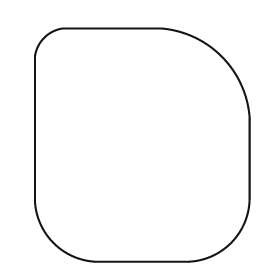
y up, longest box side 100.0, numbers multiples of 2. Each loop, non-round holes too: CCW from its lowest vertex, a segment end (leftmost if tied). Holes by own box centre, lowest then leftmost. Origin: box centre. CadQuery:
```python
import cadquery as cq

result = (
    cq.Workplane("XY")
    .moveTo(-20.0, -50.0)
    .lineTo(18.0, -50.0)
    .threePointArc((38.0, -42.0), (46.0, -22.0))
    .lineTo(46.0, 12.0)
    .threePointArc((34.0, 38.0), (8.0, 50.0))
    .lineTo(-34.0, 50.0)
    .threePointArc((-42.0, 46.0), (-46.0, 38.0))
    .lineTo(-46.0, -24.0)
    .threePointArc((-38.0, -42.0), (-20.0, -50.0))
    .close()
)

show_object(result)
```